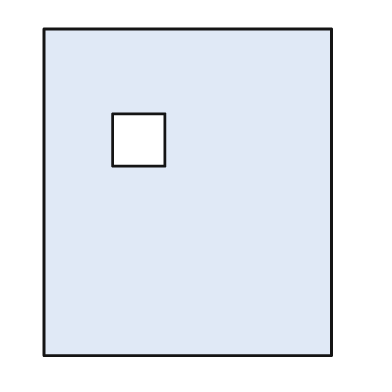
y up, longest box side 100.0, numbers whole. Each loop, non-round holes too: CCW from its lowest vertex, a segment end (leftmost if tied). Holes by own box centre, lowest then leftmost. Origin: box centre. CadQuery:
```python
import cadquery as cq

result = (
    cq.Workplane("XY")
    .moveTo(-44.0, -50.0)
    .lineTo(44.0, -50.0)
    .lineTo(44.0, 50.0)
    .lineTo(-44.0, 50.0)
    .close()
    .moveTo(-23.0, 8.0)
    .lineTo(-7.0, 8.0)
    .lineTo(-7.0, 24.0)
    .lineTo(-23.0, 24.0)
    .close()
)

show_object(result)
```